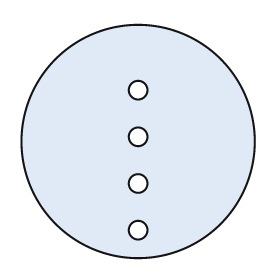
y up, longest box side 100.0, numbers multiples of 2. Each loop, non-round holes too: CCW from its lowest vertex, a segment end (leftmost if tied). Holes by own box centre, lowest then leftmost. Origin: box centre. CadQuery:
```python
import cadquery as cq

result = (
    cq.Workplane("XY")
    .moveTo(0.0, 0.0)
    .circle(50.0)
    .moveTo(0.0, -38.0)
    .circle(4.0)
    .moveTo(0.0, -18.0)
    .circle(4.0)
    .moveTo(0.0, 2.0)
    .circle(4.0)
    .moveTo(0.0, 22.0)
    .circle(4.0)
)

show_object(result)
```